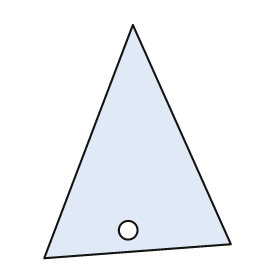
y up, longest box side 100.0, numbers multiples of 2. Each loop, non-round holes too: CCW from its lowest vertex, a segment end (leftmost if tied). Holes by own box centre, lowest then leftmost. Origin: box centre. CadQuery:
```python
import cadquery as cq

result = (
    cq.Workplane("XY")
    .moveTo(-40.0, -50.0)
    .lineTo(40.0, -44.0)
    .lineTo(-2.0, 50.0)
    .close()
    .moveTo(-4.0, -38.0)
    .circle(4.0)
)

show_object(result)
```